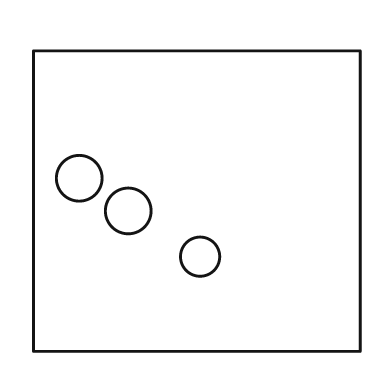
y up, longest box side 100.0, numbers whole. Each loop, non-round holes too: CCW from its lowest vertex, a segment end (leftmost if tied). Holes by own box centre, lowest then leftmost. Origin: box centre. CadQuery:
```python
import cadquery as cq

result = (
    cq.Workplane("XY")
    .moveTo(-50.0, -46.0)
    .lineTo(50.0, -46.0)
    .lineTo(50.0, 46.0)
    .lineTo(-50.0, 46.0)
    .close()
    .moveTo(1.0, -17.0)
    .circle(6.0)
    .moveTo(-21.0, -3.0)
    .circle(7.0)
    .moveTo(-36.0, 7.0)
    .circle(7.0)
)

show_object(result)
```